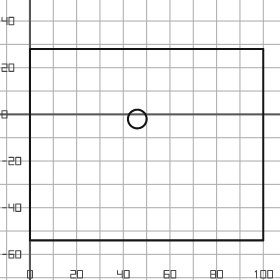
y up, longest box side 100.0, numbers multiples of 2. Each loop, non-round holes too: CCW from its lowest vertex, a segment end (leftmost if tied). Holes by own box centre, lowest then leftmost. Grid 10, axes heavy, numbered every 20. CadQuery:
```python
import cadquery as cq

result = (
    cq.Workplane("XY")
    .moveTo(0.0, -54.0)
    .lineTo(100.0, -54.0)
    .lineTo(100.0, 28.0)
    .lineTo(0.0, 28.0)
    .close()
    .moveTo(46.0, -2.0)
    .circle(4.0)
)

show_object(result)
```